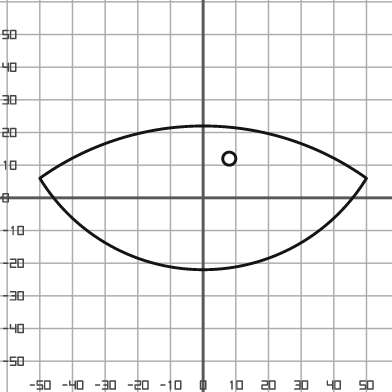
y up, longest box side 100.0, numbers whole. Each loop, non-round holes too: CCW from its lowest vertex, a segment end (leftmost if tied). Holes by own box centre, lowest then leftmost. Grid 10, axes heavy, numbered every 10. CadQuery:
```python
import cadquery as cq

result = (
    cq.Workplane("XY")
    .moveTo(-50.0, 6.0)
    .threePointArc((0.0, -22.0), (50.0, 6.0))
    .threePointArc((0.0, 22.0), (-50.0, 6.0))
    .close()
    .moveTo(8.0, 12.0)
    .circle(2.0)
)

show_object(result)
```